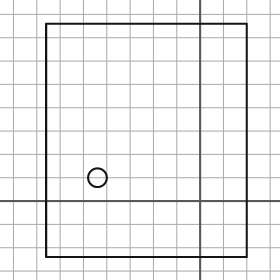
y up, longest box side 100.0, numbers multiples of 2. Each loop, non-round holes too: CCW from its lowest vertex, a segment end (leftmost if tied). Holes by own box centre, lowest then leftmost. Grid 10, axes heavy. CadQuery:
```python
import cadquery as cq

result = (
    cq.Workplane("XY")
    .moveTo(-66.0, -24.0)
    .lineTo(20.0, -24.0)
    .lineTo(20.0, 76.0)
    .lineTo(-66.0, 76.0)
    .close()
    .moveTo(-44.0, 10.0)
    .circle(4.0)
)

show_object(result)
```